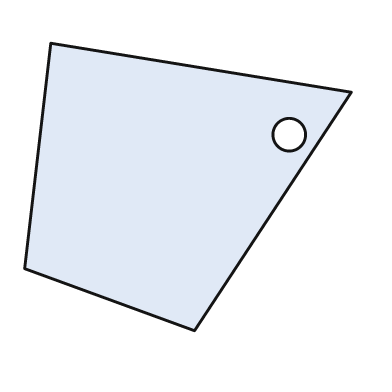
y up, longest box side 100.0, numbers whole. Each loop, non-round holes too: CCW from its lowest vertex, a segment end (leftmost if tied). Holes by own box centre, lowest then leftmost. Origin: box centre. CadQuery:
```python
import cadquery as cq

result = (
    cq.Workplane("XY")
    .moveTo(2.0, -44.0)
    .lineTo(50.0, 29.0)
    .lineTo(-42.0, 44.0)
    .lineTo(-50.0, -25.0)
    .close()
    .moveTo(31.0, 16.0)
    .circle(5.0)
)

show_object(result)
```